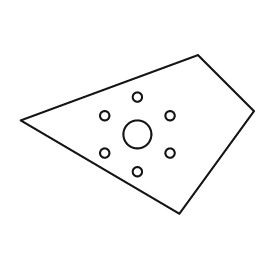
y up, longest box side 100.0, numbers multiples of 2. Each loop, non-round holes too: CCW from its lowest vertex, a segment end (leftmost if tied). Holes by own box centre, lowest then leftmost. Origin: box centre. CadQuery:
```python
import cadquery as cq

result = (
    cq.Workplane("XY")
    .moveTo(18.0, -34.0)
    .lineTo(50.0, 10.0)
    .lineTo(26.0, 34.0)
    .lineTo(-50.0, 6.0)
    .close()
    .moveTo(0.0, -16.0)
    .circle(2.0)
    .moveTo(-14.0, -8.0)
    .circle(2.0)
    .moveTo(14.0, -8.0)
    .circle(2.0)
    .moveTo(0.0, 0.0)
    .circle(6.0)
    .moveTo(-14.0, 8.0)
    .circle(2.0)
    .moveTo(14.0, 8.0)
    .circle(2.0)
    .moveTo(0.0, 16.0)
    .circle(2.0)
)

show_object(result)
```